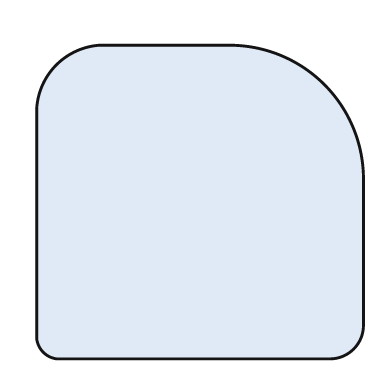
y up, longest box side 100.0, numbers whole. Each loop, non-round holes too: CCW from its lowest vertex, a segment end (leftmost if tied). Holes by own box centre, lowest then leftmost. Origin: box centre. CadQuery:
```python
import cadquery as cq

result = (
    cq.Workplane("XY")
    .moveTo(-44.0, -48.0)
    .lineTo(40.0, -48.0)
    .threePointArc((47.0, -45.0), (50.0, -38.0))
    .lineTo(50.0, 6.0)
    .threePointArc((38.0, 36.0), (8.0, 48.0))
    .lineTo(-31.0, 48.0)
    .threePointArc((-44.0, 42.0), (-50.0, 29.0))
    .lineTo(-50.0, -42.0)
    .threePointArc((-48.0, -46.0), (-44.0, -48.0))
    .close()
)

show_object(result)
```